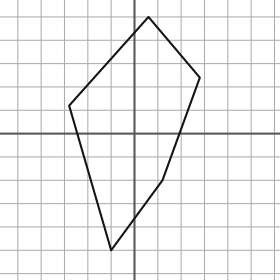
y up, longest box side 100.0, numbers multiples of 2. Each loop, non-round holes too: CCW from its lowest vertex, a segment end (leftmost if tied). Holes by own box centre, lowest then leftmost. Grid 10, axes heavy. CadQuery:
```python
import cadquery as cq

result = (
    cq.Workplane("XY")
    .moveTo(-10.0, -50.0)
    .lineTo(12.0, -20.0)
    .lineTo(28.0, 24.0)
    .lineTo(6.0, 50.0)
    .lineTo(-28.0, 12.0)
    .close()
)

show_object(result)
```